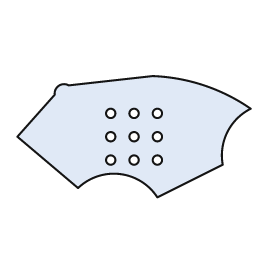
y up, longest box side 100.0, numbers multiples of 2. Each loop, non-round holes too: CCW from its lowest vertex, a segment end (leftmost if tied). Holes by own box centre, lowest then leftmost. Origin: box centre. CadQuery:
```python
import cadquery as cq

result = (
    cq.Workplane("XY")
    .moveTo(10.0, -26.0)
    .lineTo(38.0, -12.0)
    .threePointArc((40.0, 2.0), (50.0, 12.0))
    .threePointArc((30.0, 22.0), (8.0, 26.0))
    .lineTo(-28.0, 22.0)
    .threePointArc((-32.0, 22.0), (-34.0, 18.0))
    .lineTo(-50.0, 0.0)
    .lineTo(-24.0, -22.0)
    .threePointArc((-6.0, -16.0), (10.0, -26.0))
    .close()
    .moveTo(-10.0, -10.0)
    .circle(2.0)
    .moveTo(0.0, -10.0)
    .circle(2.0)
    .moveTo(10.0, -10.0)
    .circle(2.0)
    .moveTo(-10.0, 0.0)
    .circle(2.0)
    .moveTo(0.0, 0.0)
    .circle(2.0)
    .moveTo(10.0, 0.0)
    .circle(2.0)
    .moveTo(-10.0, 10.0)
    .circle(2.0)
    .moveTo(0.0, 10.0)
    .circle(2.0)
    .moveTo(10.0, 10.0)
    .circle(2.0)
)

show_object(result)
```